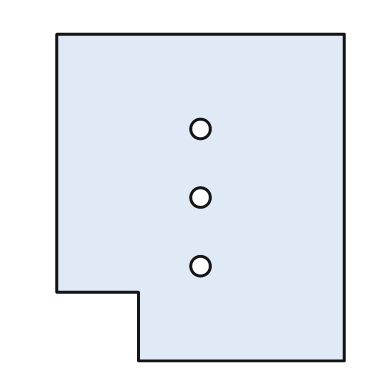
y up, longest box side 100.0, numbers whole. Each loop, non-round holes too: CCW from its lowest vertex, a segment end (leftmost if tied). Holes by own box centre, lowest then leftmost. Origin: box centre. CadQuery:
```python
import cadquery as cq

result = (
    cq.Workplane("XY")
    .moveTo(-19.0, -50.0)
    .lineTo(44.0, -50.0)
    .lineTo(44.0, 50.0)
    .lineTo(-44.0, 50.0)
    .lineTo(-44.0, -29.0)
    .lineTo(-19.0, -29.0)
    .close()
    .moveTo(0.0, -21.0)
    .circle(3.0)
    .moveTo(0.0, 0.0)
    .circle(3.0)
    .moveTo(0.0, 21.0)
    .circle(3.0)
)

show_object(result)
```